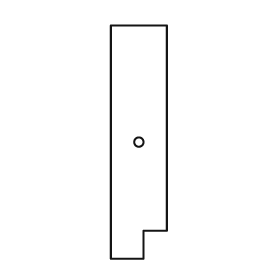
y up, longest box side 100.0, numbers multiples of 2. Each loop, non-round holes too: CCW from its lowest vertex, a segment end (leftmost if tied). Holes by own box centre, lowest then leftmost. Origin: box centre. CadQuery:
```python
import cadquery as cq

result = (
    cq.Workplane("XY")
    .moveTo(-12.0, -50.0)
    .lineTo(2.0, -50.0)
    .lineTo(2.0, -38.0)
    .lineTo(12.0, -38.0)
    .lineTo(12.0, 50.0)
    .lineTo(-12.0, 50.0)
    .close()
    .moveTo(0.0, 0.0)
    .circle(2.0)
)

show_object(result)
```